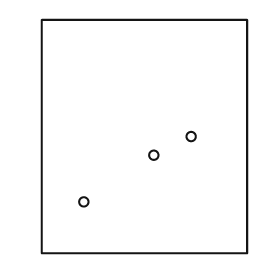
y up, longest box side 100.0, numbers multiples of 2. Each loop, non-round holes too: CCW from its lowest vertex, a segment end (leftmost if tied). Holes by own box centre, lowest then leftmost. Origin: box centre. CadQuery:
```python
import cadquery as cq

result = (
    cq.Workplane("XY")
    .moveTo(-44.0, -50.0)
    .lineTo(44.0, -50.0)
    .lineTo(44.0, 50.0)
    .lineTo(-44.0, 50.0)
    .close()
    .moveTo(-26.0, -28.0)
    .circle(2.0)
    .moveTo(4.0, -8.0)
    .circle(2.0)
    .moveTo(20.0, 0.0)
    .circle(2.0)
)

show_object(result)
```